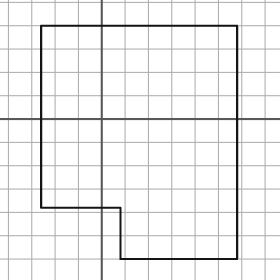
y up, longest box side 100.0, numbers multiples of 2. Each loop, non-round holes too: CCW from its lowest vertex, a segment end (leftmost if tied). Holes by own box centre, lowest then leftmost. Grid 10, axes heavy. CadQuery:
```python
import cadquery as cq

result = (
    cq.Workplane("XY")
    .moveTo(8.0, -60.0)
    .lineTo(58.0, -60.0)
    .lineTo(58.0, 40.0)
    .lineTo(-26.0, 40.0)
    .lineTo(-26.0, -38.0)
    .lineTo(8.0, -38.0)
    .close()
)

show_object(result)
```